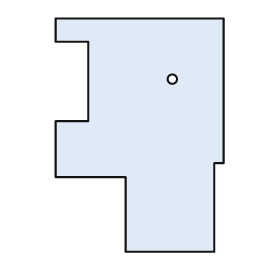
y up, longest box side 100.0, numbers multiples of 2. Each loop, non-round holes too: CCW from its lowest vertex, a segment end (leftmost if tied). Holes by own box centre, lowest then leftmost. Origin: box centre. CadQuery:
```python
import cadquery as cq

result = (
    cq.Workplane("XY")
    .moveTo(-6.0, -50.0)
    .lineTo(32.0, -50.0)
    .lineTo(32.0, -12.0)
    .lineTo(36.0, -12.0)
    .lineTo(36.0, 50.0)
    .lineTo(-36.0, 50.0)
    .lineTo(-36.0, 40.0)
    .lineTo(-22.0, 40.0)
    .lineTo(-22.0, 6.0)
    .lineTo(-36.0, 6.0)
    .lineTo(-36.0, -18.0)
    .lineTo(-6.0, -18.0)
    .close()
    .moveTo(14.0, 24.0)
    .circle(2.0)
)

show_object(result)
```